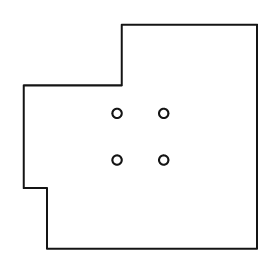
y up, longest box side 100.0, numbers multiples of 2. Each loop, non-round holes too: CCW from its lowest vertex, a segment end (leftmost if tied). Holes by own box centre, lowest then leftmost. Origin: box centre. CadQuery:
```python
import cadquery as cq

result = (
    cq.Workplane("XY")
    .moveTo(-40.0, -48.0)
    .lineTo(50.0, -48.0)
    .lineTo(50.0, 48.0)
    .lineTo(-8.0, 48.0)
    .lineTo(-8.0, 22.0)
    .lineTo(-50.0, 22.0)
    .lineTo(-50.0, -22.0)
    .lineTo(-40.0, -22.0)
    .close()
    .moveTo(-10.0, -10.0)
    .circle(2.0)
    .moveTo(10.0, -10.0)
    .circle(2.0)
    .moveTo(-10.0, 10.0)
    .circle(2.0)
    .moveTo(10.0, 10.0)
    .circle(2.0)
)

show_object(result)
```